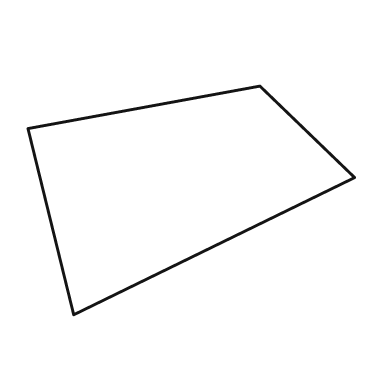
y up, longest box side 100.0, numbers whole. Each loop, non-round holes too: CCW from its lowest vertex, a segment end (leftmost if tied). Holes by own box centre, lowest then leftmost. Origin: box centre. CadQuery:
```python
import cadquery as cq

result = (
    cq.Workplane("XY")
    .moveTo(-36.0, -35.0)
    .lineTo(50.0, 7.0)
    .lineTo(21.0, 35.0)
    .lineTo(-50.0, 22.0)
    .close()
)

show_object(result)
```